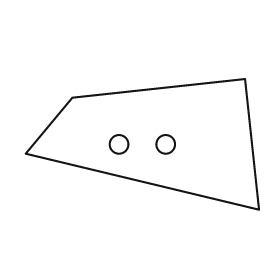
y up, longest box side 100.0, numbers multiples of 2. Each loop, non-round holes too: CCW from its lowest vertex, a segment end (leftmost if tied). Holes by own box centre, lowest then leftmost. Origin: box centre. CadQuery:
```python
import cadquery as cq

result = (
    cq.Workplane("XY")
    .moveTo(50.0, -28.0)
    .lineTo(44.0, 28.0)
    .lineTo(-30.0, 20.0)
    .lineTo(-50.0, -4.0)
    .close()
    .moveTo(-10.0, 0.0)
    .circle(4.0)
    .moveTo(10.0, 0.0)
    .circle(4.0)
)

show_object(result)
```